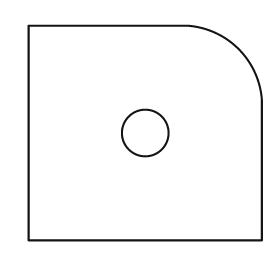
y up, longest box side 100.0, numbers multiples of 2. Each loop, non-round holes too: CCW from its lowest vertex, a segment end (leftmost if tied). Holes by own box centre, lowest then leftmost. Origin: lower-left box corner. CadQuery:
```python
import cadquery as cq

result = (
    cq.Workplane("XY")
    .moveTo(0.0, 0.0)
    .lineTo(100.0, 0.0)
    .lineTo(100.0, 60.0)
    .threePointArc((90.0, 82.0), (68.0, 92.0))
    .lineTo(0.0, 92.0)
    .close()
    .moveTo(50.0, 46.0)
    .circle(10.0)
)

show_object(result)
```